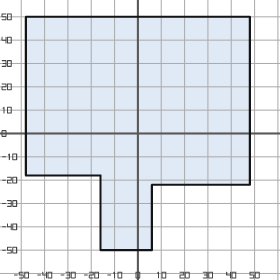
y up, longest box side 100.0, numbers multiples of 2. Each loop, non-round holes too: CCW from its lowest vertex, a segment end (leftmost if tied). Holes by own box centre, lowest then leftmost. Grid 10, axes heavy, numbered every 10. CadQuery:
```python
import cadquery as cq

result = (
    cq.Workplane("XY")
    .moveTo(-16.0, -50.0)
    .lineTo(6.0, -50.0)
    .lineTo(6.0, -22.0)
    .lineTo(48.0, -22.0)
    .lineTo(48.0, 50.0)
    .lineTo(-48.0, 50.0)
    .lineTo(-48.0, -18.0)
    .lineTo(-16.0, -18.0)
    .close()
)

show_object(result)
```